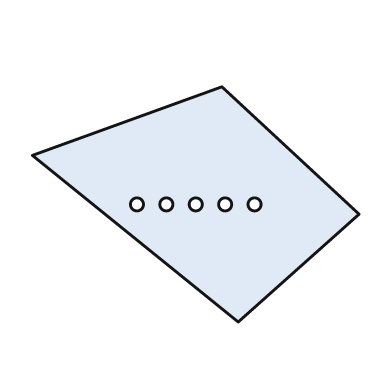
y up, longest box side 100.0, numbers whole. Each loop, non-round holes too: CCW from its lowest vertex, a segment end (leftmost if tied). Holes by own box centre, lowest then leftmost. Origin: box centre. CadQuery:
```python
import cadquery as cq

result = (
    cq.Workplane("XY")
    .moveTo(13.0, -36.0)
    .lineTo(50.0, -3.0)
    .lineTo(8.0, 36.0)
    .lineTo(-50.0, 15.0)
    .close()
    .moveTo(-18.0, 0.0)
    .circle(2.0)
    .moveTo(-9.0, 0.0)
    .circle(2.0)
    .moveTo(0.0, 0.0)
    .circle(2.0)
    .moveTo(9.0, 0.0)
    .circle(2.0)
    .moveTo(18.0, 0.0)
    .circle(2.0)
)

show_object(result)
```